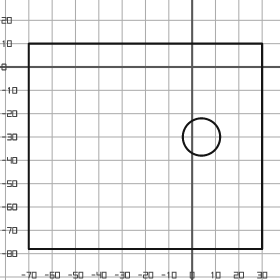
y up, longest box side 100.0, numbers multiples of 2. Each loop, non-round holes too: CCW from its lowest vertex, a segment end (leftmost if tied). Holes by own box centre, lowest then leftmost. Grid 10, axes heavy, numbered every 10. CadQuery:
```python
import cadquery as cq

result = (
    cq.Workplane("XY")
    .moveTo(-70.0, -78.0)
    .lineTo(30.0, -78.0)
    .lineTo(30.0, 10.0)
    .lineTo(-70.0, 10.0)
    .close()
    .moveTo(4.0, -30.0)
    .circle(8.0)
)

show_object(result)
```